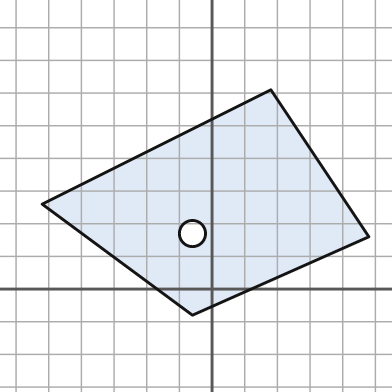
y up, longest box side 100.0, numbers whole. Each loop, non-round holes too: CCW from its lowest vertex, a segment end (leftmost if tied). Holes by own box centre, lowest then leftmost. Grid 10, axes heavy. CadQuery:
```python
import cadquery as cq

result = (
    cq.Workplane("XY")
    .moveTo(-6.0, -8.0)
    .lineTo(48.0, 16.0)
    .lineTo(18.0, 61.0)
    .lineTo(-52.0, 26.0)
    .close()
    .moveTo(-6.0, 17.0)
    .circle(4.0)
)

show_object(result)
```